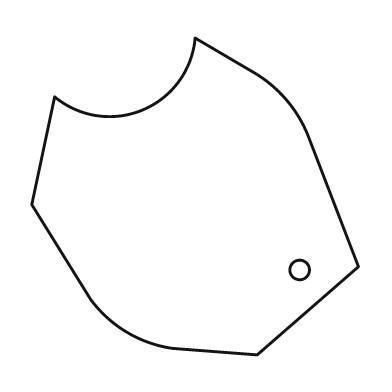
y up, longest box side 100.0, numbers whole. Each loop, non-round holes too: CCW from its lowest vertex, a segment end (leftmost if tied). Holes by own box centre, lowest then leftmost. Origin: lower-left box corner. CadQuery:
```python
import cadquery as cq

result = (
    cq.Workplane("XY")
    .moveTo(69.0, 0.0)
    .lineTo(100.0, 27.0)
    .lineTo(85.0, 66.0)
    .threePointArc((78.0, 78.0), (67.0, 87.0))
    .lineTo(50.0, 97.0)
    .threePointArc((34.0, 75.0), (7.0, 79.0))
    .lineTo(0.0, 46.0)
    .lineTo(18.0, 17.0)
    .threePointArc((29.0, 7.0), (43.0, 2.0))
    .close()
    .moveTo(82.0, 26.0)
    .circle(3.0)
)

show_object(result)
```